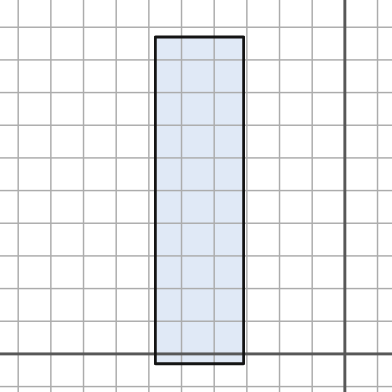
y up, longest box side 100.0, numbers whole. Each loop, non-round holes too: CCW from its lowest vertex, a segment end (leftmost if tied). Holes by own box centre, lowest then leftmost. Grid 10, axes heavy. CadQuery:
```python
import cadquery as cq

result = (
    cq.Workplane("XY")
    .moveTo(-58.0, -3.0)
    .lineTo(-31.0, -3.0)
    .lineTo(-31.0, 97.0)
    .lineTo(-58.0, 97.0)
    .close()
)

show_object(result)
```